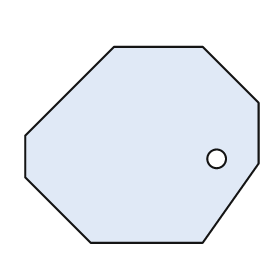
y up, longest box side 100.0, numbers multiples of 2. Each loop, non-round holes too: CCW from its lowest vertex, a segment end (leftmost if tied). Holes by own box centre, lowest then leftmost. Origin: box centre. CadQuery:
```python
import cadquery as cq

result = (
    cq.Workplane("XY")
    .moveTo(-22.0, -42.0)
    .lineTo(26.0, -42.0)
    .lineTo(50.0, -8.0)
    .lineTo(50.0, 18.0)
    .lineTo(26.0, 42.0)
    .lineTo(-12.0, 42.0)
    .lineTo(-50.0, 4.0)
    .lineTo(-50.0, -14.0)
    .close()
    .moveTo(32.0, -6.0)
    .circle(4.0)
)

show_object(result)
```